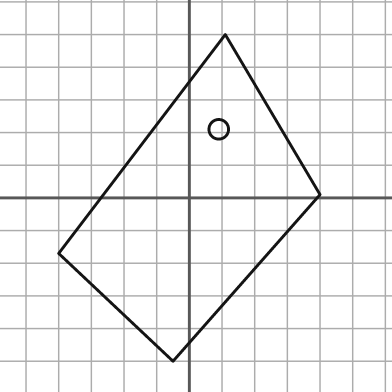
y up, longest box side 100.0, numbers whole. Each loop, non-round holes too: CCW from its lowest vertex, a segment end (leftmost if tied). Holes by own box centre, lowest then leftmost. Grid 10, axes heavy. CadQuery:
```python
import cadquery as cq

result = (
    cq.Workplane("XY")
    .moveTo(-5.0, -50.0)
    .lineTo(40.0, 1.0)
    .lineTo(11.0, 50.0)
    .lineTo(-40.0, -17.0)
    .close()
    .moveTo(9.0, 21.0)
    .circle(3.0)
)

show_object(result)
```